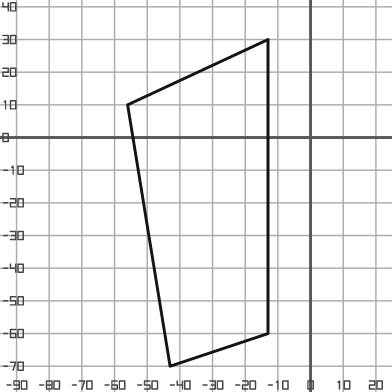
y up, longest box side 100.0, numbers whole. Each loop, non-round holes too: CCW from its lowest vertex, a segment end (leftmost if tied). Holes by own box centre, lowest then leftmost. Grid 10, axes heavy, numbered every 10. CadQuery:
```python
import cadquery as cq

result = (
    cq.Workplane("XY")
    .moveTo(-43.0, -70.0)
    .lineTo(-13.0, -60.0)
    .lineTo(-13.0, 30.0)
    .lineTo(-56.0, 10.0)
    .close()
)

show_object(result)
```